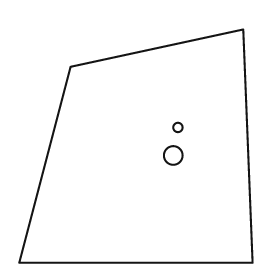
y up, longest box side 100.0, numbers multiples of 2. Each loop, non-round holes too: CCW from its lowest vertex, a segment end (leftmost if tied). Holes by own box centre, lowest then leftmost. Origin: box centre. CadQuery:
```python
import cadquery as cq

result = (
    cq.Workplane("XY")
    .moveTo(-50.0, -50.0)
    .lineTo(50.0, -50.0)
    .lineTo(46.0, 50.0)
    .lineTo(-28.0, 34.0)
    .close()
    .moveTo(16.0, -4.0)
    .circle(4.0)
    .moveTo(18.0, 8.0)
    .circle(2.0)
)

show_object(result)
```